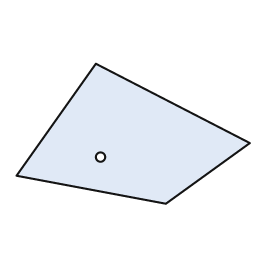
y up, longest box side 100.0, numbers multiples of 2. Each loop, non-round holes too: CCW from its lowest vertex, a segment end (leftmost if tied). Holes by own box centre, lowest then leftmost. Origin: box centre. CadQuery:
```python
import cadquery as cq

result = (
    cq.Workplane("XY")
    .moveTo(14.0, -30.0)
    .lineTo(50.0, -4.0)
    .lineTo(-16.0, 30.0)
    .lineTo(-50.0, -18.0)
    .close()
    .moveTo(-14.0, -10.0)
    .circle(2.0)
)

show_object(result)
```